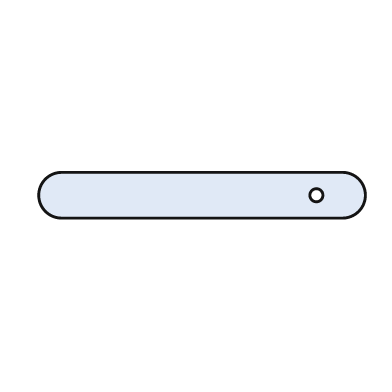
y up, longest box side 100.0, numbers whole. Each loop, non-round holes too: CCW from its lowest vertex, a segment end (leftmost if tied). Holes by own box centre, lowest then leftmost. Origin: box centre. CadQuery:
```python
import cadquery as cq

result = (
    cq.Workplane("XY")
    .moveTo(-43.0, -7.0)
    .lineTo(43.0, -7.0)
    .threePointArc((50.0, 0.0), (43.0, 7.0))
    .lineTo(-43.0, 7.0)
    .threePointArc((-50.0, 0.0), (-43.0, -7.0))
    .close()
    .moveTo(35.0, 0.0)
    .circle(2.0)
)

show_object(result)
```